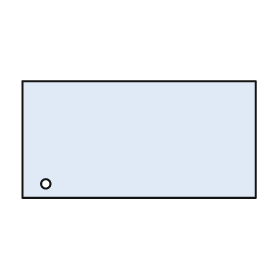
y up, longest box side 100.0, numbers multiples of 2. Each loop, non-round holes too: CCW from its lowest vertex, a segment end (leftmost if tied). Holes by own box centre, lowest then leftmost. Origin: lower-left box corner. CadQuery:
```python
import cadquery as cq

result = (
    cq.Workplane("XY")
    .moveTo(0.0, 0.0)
    .lineTo(100.0, 0.0)
    .lineTo(100.0, 50.0)
    .lineTo(0.0, 50.0)
    .close()
    .moveTo(10.0, 6.0)
    .circle(2.0)
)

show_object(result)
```